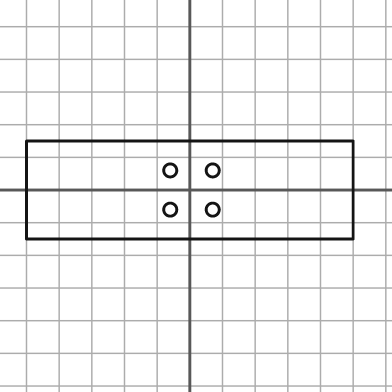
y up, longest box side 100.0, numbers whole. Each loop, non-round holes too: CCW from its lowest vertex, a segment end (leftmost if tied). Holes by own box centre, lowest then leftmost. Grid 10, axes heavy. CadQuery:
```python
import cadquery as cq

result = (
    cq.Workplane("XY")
    .moveTo(-50.0, -15.0)
    .lineTo(50.0, -15.0)
    .lineTo(50.0, 15.0)
    .lineTo(-50.0, 15.0)
    .close()
    .moveTo(-6.0, -6.0)
    .circle(2.0)
    .moveTo(7.0, -6.0)
    .circle(2.0)
    .moveTo(-6.0, 6.0)
    .circle(2.0)
    .moveTo(7.0, 6.0)
    .circle(2.0)
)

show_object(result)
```